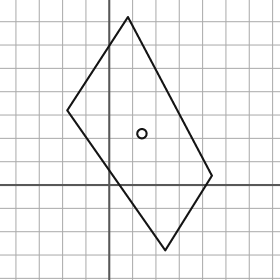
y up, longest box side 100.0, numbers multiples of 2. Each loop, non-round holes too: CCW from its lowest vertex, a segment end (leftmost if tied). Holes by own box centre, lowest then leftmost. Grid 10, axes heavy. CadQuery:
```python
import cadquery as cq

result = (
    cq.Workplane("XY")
    .moveTo(24.0, -28.0)
    .lineTo(44.0, 4.0)
    .lineTo(8.0, 72.0)
    .lineTo(-18.0, 32.0)
    .close()
    .moveTo(14.0, 22.0)
    .circle(2.0)
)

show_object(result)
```